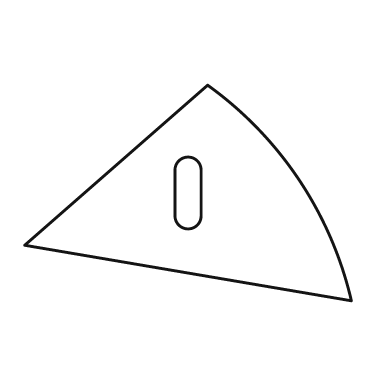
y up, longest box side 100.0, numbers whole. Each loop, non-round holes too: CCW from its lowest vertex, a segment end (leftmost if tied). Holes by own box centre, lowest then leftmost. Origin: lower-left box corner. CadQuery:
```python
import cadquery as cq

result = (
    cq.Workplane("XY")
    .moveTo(100.0, 0.0)
    .threePointArc((84.0, 37.0), (56.0, 66.0))
    .lineTo(0.0, 17.0)
    .close()
    .moveTo(46.0, 26.0)
    .threePointArc((50.0, 22.0), (54.0, 26.0))
    .lineTo(54.0, 40.0)
    .threePointArc((50.0, 44.0), (46.0, 40.0))
    .close()
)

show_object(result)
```